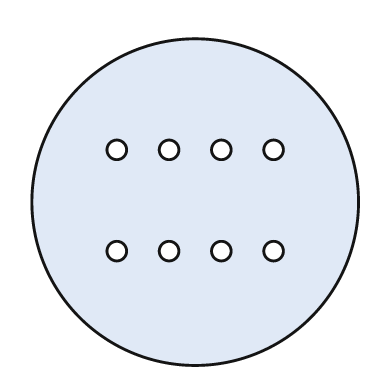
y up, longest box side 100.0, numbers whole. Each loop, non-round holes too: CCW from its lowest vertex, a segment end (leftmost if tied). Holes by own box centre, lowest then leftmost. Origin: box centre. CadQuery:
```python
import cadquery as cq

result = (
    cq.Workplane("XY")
    .moveTo(0.0, 0.0)
    .circle(50.0)
    .moveTo(-24.0, -15.0)
    .circle(3.0)
    .moveTo(-8.0, -15.0)
    .circle(3.0)
    .moveTo(8.0, -15.0)
    .circle(3.0)
    .moveTo(24.0, -15.0)
    .circle(3.0)
    .moveTo(-24.0, 16.0)
    .circle(3.0)
    .moveTo(-8.0, 16.0)
    .circle(3.0)
    .moveTo(8.0, 16.0)
    .circle(3.0)
    .moveTo(24.0, 16.0)
    .circle(3.0)
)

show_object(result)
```